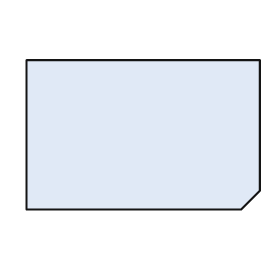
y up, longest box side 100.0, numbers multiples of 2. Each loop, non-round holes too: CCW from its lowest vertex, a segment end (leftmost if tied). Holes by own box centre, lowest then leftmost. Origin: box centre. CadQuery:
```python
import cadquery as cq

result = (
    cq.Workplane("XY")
    .moveTo(-50.0, -32.0)
    .lineTo(42.0, -32.0)
    .lineTo(50.0, -24.0)
    .lineTo(50.0, 32.0)
    .lineTo(-50.0, 32.0)
    .close()
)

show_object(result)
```